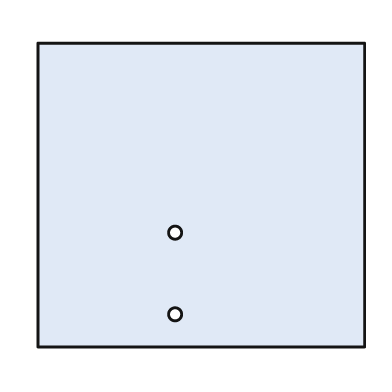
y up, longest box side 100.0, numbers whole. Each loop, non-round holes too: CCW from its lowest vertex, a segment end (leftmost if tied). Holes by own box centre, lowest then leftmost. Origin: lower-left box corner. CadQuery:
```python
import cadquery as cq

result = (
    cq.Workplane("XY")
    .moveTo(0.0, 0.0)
    .lineTo(100.0, 0.0)
    .lineTo(100.0, 93.0)
    .lineTo(0.0, 93.0)
    .close()
    .moveTo(42.0, 10.0)
    .circle(2.0)
    .moveTo(42.0, 35.0)
    .circle(2.0)
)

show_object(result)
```